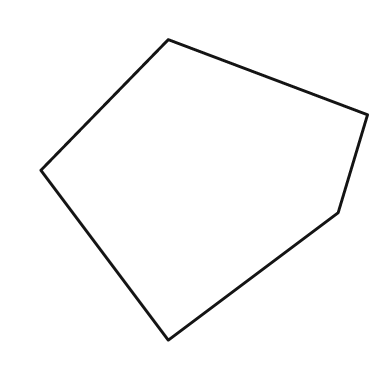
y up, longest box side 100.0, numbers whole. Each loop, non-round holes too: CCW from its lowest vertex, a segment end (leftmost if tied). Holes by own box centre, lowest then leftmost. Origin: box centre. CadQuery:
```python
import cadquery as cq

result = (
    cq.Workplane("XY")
    .moveTo(-11.0, -46.0)
    .lineTo(41.0, -7.0)
    .lineTo(50.0, 23.0)
    .lineTo(-11.0, 46.0)
    .lineTo(-50.0, 6.0)
    .close()
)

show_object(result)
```